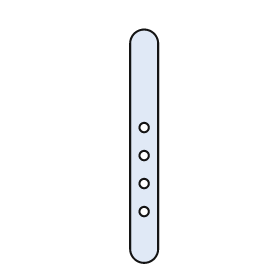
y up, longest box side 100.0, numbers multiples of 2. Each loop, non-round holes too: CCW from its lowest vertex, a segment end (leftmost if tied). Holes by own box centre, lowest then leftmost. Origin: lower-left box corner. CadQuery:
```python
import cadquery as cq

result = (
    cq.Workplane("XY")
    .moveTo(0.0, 6.0)
    .threePointArc((6.0, 0.0), (12.0, 6.0))
    .lineTo(12.0, 94.0)
    .threePointArc((6.0, 100.0), (0.0, 94.0))
    .close()
    .moveTo(6.0, 22.0)
    .circle(2.0)
    .moveTo(6.0, 34.0)
    .circle(2.0)
    .moveTo(6.0, 46.0)
    .circle(2.0)
    .moveTo(6.0, 58.0)
    .circle(2.0)
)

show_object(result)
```